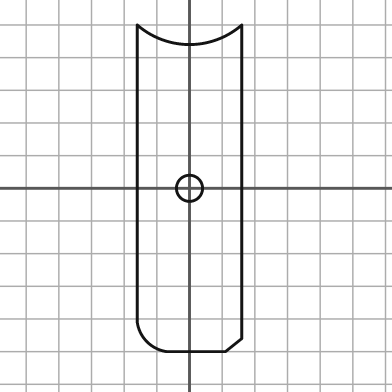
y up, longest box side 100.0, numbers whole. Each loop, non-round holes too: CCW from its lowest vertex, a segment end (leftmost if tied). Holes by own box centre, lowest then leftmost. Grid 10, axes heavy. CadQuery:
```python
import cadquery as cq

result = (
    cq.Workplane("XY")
    .moveTo(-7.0, -50.0)
    .lineTo(11.0, -50.0)
    .lineTo(16.0, -46.0)
    .lineTo(16.0, 50.0)
    .threePointArc((0.0, 44.0), (-16.0, 50.0))
    .lineTo(-16.0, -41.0)
    .threePointArc((-13.0, -47.0), (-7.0, -50.0))
    .close()
    .moveTo(0.0, 0.0)
    .circle(4.0)
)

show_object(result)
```